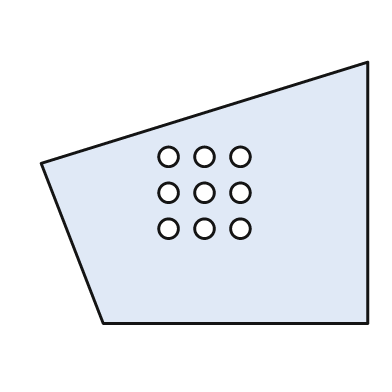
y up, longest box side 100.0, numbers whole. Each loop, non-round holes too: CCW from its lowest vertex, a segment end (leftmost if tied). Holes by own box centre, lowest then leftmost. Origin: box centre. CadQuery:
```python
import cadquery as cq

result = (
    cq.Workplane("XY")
    .moveTo(-31.0, -40.0)
    .lineTo(50.0, -40.0)
    .lineTo(50.0, 40.0)
    .lineTo(-50.0, 9.0)
    .close()
    .moveTo(-11.0, -11.0)
    .circle(3.0)
    .moveTo(0.0, -11.0)
    .circle(3.0)
    .moveTo(11.0, -11.0)
    .circle(3.0)
    .moveTo(-11.0, 0.0)
    .circle(3.0)
    .moveTo(0.0, 0.0)
    .circle(3.0)
    .moveTo(11.0, 0.0)
    .circle(3.0)
    .moveTo(-11.0, 11.0)
    .circle(3.0)
    .moveTo(0.0, 11.0)
    .circle(3.0)
    .moveTo(11.0, 11.0)
    .circle(3.0)
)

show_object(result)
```